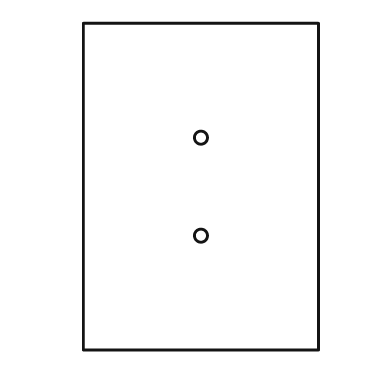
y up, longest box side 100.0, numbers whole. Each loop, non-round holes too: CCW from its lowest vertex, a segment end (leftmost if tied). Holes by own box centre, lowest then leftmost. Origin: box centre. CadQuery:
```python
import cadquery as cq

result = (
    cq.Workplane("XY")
    .moveTo(-36.0, -50.0)
    .lineTo(36.0, -50.0)
    .lineTo(36.0, 50.0)
    .lineTo(-36.0, 50.0)
    .close()
    .moveTo(0.0, -15.0)
    .circle(2.0)
    .moveTo(0.0, 15.0)
    .circle(2.0)
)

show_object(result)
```